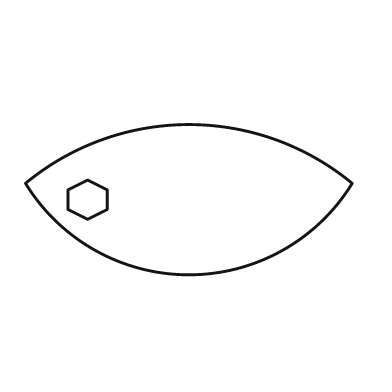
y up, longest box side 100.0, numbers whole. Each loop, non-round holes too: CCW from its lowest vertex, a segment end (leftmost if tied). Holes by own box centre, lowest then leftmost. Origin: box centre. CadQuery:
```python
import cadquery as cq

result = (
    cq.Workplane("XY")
    .moveTo(-50.0, 5.0)
    .threePointArc((0.0, -23.0), (50.0, 5.0))
    .threePointArc((0.0, 23.0), (-50.0, 5.0))
    .close()
    .moveTo(-31.0, -6.0)
    .lineTo(-25.0, -3.0)
    .lineTo(-25.0, 3.0)
    .lineTo(-31.0, 6.0)
    .lineTo(-37.0, 3.0)
    .lineTo(-37.0, -3.0)
    .close()
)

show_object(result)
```